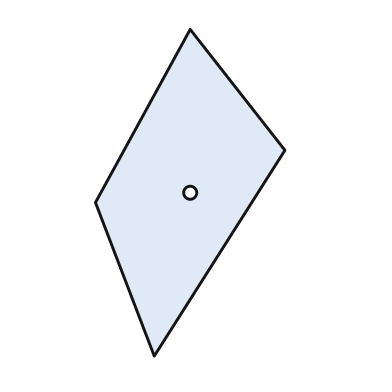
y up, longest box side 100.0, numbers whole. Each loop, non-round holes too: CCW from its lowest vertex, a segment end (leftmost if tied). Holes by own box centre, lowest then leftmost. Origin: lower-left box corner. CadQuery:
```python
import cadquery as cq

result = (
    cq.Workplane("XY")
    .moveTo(18.0, 0.0)
    .lineTo(58.0, 63.0)
    .lineTo(29.0, 100.0)
    .lineTo(0.0, 47.0)
    .close()
    .moveTo(29.0, 50.0)
    .circle(2.0)
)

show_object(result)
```